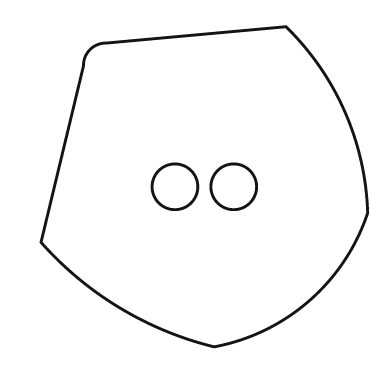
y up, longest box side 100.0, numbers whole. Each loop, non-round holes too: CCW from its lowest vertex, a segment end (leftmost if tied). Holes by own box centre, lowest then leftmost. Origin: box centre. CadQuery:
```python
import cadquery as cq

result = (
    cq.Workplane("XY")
    .moveTo(3.0, -49.0)
    .threePointArc((32.0, -35.0), (50.0, -8.0))
    .threePointArc((43.0, 23.0), (25.0, 49.0))
    .lineTo(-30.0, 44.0)
    .threePointArc((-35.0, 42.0), (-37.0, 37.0))
    .lineTo(-50.0, -17.0)
    .threePointArc((-26.0, -37.0), (3.0, -49.0))
    .close()
    .moveTo(-9.0, 0.0)
    .circle(7.0)
    .moveTo(9.0, 0.0)
    .circle(7.0)
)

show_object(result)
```